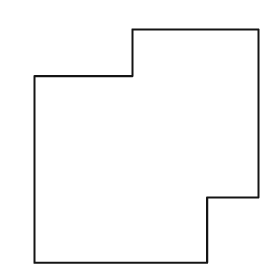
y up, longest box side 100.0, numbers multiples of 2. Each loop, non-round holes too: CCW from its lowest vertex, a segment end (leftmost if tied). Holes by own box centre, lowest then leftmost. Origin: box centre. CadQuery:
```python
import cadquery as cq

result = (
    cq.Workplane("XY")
    .moveTo(-48.0, -50.0)
    .lineTo(26.0, -50.0)
    .lineTo(26.0, -22.0)
    .lineTo(48.0, -22.0)
    .lineTo(48.0, 50.0)
    .lineTo(-6.0, 50.0)
    .lineTo(-6.0, 30.0)
    .lineTo(-48.0, 30.0)
    .close()
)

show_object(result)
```